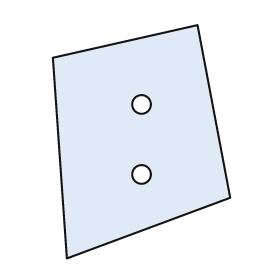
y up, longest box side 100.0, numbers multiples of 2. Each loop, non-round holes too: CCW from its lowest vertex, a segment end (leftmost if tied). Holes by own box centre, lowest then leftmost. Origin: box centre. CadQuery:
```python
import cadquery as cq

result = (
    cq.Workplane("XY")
    .moveTo(-32.0, -50.0)
    .lineTo(38.0, -24.0)
    .lineTo(24.0, 50.0)
    .lineTo(-38.0, 36.0)
    .close()
    .moveTo(0.0, -14.0)
    .circle(4.0)
    .moveTo(0.0, 16.0)
    .circle(4.0)
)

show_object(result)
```